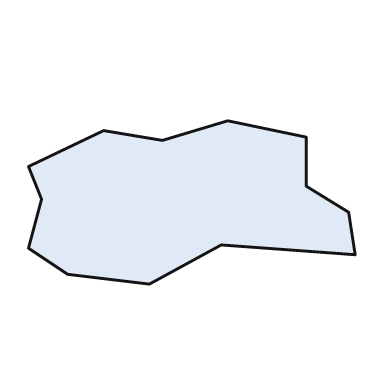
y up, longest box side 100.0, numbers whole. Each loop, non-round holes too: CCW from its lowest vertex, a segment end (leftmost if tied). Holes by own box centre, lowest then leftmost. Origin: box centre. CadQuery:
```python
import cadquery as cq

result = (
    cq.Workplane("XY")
    .moveTo(-13.0, -25.0)
    .lineTo(9.0, -13.0)
    .lineTo(50.0, -16.0)
    .lineTo(48.0, -3.0)
    .lineTo(35.0, 5.0)
    .lineTo(35.0, 20.0)
    .lineTo(11.0, 25.0)
    .lineTo(-9.0, 19.0)
    .lineTo(-27.0, 22.0)
    .lineTo(-50.0, 11.0)
    .lineTo(-46.0, 1.0)
    .lineTo(-50.0, -14.0)
    .lineTo(-38.0, -22.0)
    .close()
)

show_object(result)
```